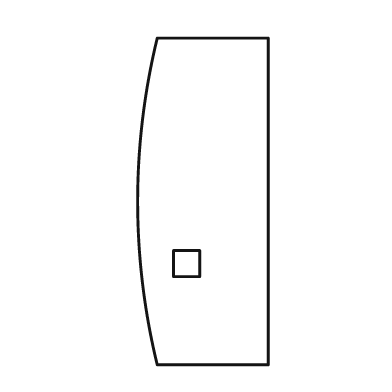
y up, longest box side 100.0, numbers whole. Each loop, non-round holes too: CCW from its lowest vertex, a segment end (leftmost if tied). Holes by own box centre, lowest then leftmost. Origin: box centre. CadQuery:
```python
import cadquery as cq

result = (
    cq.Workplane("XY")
    .moveTo(-14.0, -50.0)
    .lineTo(20.0, -50.0)
    .lineTo(20.0, 50.0)
    .lineTo(-14.0, 50.0)
    .threePointArc((-20.0, 0.0), (-14.0, -50.0))
    .close()
    .moveTo(-9.0, -23.0)
    .lineTo(-1.0, -23.0)
    .lineTo(-1.0, -15.0)
    .lineTo(-9.0, -15.0)
    .close()
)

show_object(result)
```